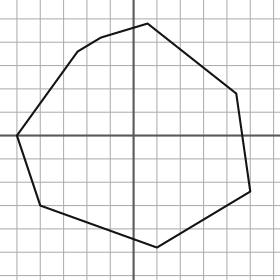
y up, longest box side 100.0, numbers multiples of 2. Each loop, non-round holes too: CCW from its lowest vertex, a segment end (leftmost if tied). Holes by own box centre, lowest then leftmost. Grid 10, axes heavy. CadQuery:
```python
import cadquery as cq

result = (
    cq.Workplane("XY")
    .moveTo(10.0, -48.0)
    .lineTo(50.0, -24.0)
    .lineTo(44.0, 18.0)
    .lineTo(6.0, 48.0)
    .lineTo(-14.0, 42.0)
    .lineTo(-24.0, 36.0)
    .lineTo(-50.0, 0.0)
    .lineTo(-40.0, -30.0)
    .close()
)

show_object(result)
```